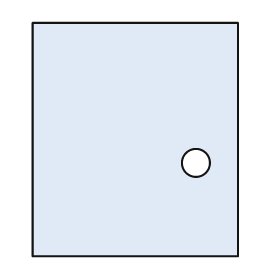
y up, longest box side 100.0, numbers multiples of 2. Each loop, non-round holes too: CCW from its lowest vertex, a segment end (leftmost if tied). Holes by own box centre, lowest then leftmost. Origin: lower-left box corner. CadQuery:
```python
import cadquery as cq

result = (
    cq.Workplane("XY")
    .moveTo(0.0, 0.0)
    .lineTo(88.0, 0.0)
    .lineTo(88.0, 100.0)
    .lineTo(0.0, 100.0)
    .close()
    .moveTo(70.0, 40.0)
    .circle(6.0)
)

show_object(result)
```